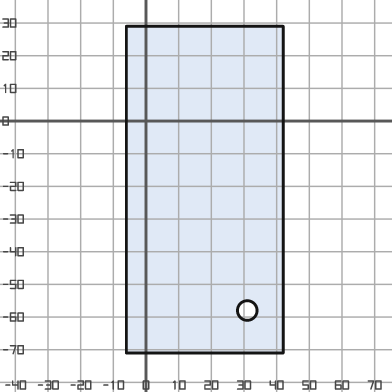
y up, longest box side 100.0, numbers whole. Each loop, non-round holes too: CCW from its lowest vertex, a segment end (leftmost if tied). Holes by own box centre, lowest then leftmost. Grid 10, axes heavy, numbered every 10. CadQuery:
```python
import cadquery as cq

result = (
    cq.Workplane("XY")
    .moveTo(-6.0, -71.0)
    .lineTo(42.0, -71.0)
    .lineTo(42.0, 29.0)
    .lineTo(-6.0, 29.0)
    .close()
    .moveTo(31.0, -58.0)
    .circle(3.0)
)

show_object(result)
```